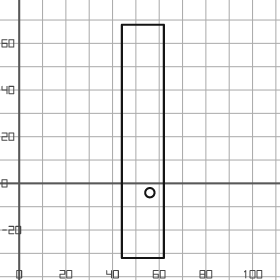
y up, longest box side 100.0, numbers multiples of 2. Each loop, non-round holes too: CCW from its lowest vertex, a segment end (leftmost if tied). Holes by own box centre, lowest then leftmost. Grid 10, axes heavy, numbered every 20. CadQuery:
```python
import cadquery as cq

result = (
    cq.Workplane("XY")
    .moveTo(44.0, -32.0)
    .lineTo(62.0, -32.0)
    .lineTo(62.0, 68.0)
    .lineTo(44.0, 68.0)
    .close()
    .moveTo(56.0, -4.0)
    .circle(2.0)
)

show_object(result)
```